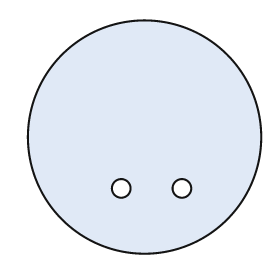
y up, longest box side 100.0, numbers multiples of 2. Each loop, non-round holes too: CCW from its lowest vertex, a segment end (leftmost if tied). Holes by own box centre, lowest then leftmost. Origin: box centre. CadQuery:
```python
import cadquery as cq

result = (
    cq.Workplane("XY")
    .moveTo(0.0, 0.0)
    .circle(50.0)
    .moveTo(-10.0, -22.0)
    .circle(4.0)
    .moveTo(16.0, -22.0)
    .circle(4.0)
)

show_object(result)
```